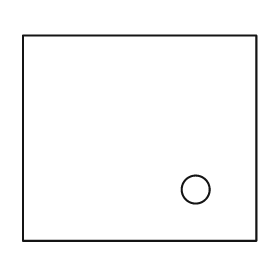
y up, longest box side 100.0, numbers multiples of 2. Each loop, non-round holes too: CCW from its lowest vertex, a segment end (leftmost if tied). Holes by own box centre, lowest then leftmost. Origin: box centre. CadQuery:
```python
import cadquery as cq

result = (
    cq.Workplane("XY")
    .moveTo(-50.0, -44.0)
    .lineTo(50.0, -44.0)
    .lineTo(50.0, 44.0)
    .lineTo(-50.0, 44.0)
    .close()
    .moveTo(24.0, -22.0)
    .circle(6.0)
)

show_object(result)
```